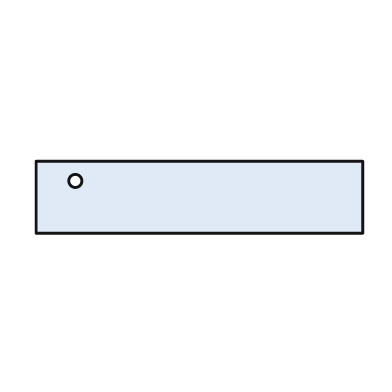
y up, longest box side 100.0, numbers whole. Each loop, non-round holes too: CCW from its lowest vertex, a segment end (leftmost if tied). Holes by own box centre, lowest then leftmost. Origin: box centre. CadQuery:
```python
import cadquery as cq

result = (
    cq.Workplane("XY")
    .moveTo(-50.0, -11.0)
    .lineTo(50.0, -11.0)
    .lineTo(50.0, 11.0)
    .lineTo(-50.0, 11.0)
    .close()
    .moveTo(-38.0, 5.0)
    .circle(2.0)
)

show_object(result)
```